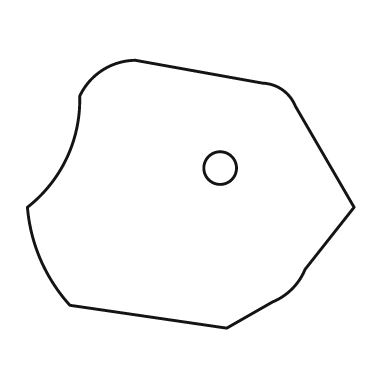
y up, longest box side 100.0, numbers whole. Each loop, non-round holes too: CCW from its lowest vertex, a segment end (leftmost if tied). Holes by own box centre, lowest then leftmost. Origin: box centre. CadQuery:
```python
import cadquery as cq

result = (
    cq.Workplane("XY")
    .moveTo(11.0, -41.0)
    .lineTo(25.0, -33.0)
    .threePointArc((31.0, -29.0), (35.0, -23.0))
    .lineTo(50.0, -4.0)
    .lineTo(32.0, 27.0)
    .threePointArc((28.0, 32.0), (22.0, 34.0))
    .lineTo(-17.0, 41.0)
    .threePointArc((-27.0, 38.0), (-34.0, 30.0))
    .threePointArc((-38.0, 11.0), (-50.0, -4.0))
    .threePointArc((-46.0, -20.0), (-37.0, -34.0))
    .close()
    .moveTo(9.0, 8.0)
    .circle(5.0)
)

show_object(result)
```